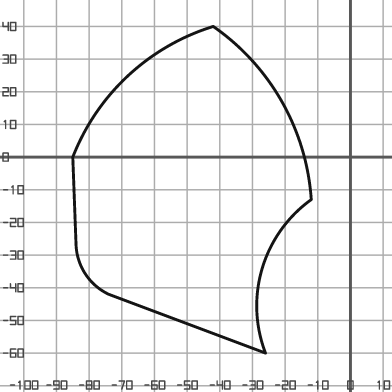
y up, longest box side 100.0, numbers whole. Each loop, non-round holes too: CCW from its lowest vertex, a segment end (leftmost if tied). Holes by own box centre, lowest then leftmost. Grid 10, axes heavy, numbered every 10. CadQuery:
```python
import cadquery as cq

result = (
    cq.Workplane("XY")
    .moveTo(-26.0, -60.0)
    .threePointArc((-27.0, -34.0), (-12.0, -13.0))
    .threePointArc((-21.0, 17.0), (-42.0, 40.0))
    .threePointArc((-68.0, 25.0), (-85.0, 0.0))
    .lineTo(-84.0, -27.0)
    .threePointArc((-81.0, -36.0), (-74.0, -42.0))
    .close()
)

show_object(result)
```